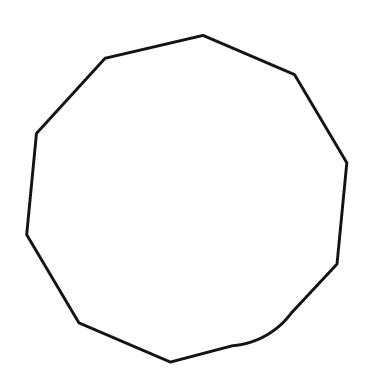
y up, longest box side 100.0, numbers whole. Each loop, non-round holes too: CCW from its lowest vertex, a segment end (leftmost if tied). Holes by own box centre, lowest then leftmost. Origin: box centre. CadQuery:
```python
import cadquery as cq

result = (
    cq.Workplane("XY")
    .moveTo(-5.0, -50.0)
    .lineTo(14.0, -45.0)
    .threePointArc((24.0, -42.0), (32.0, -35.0))
    .lineTo(46.0, -20.0)
    .lineTo(49.0, 11.0)
    .lineTo(33.0, 38.0)
    .lineTo(5.0, 50.0)
    .lineTo(-25.0, 43.0)
    .lineTo(-46.0, 20.0)
    .lineTo(-49.0, -11.0)
    .lineTo(-33.0, -38.0)
    .close()
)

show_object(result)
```